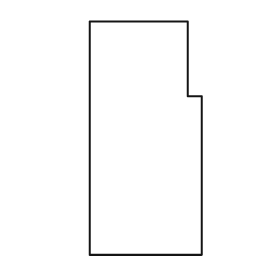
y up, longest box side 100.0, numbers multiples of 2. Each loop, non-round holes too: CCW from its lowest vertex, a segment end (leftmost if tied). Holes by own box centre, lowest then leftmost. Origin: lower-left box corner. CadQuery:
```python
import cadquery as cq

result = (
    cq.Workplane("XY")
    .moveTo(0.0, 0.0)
    .lineTo(48.0, 0.0)
    .lineTo(48.0, 68.0)
    .lineTo(42.0, 68.0)
    .lineTo(42.0, 100.0)
    .lineTo(0.0, 100.0)
    .close()
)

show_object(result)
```